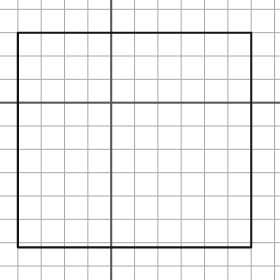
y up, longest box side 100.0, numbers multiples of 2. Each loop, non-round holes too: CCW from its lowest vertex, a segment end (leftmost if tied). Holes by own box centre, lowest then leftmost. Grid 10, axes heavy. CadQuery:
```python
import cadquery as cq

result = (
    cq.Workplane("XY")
    .moveTo(-40.0, -62.0)
    .lineTo(60.0, -62.0)
    .lineTo(60.0, 30.0)
    .lineTo(-40.0, 30.0)
    .close()
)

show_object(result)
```